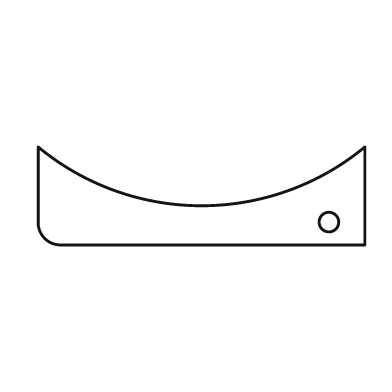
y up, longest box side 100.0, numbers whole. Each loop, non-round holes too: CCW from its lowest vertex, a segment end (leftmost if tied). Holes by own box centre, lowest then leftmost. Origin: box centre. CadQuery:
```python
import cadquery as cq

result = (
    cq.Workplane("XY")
    .moveTo(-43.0, -15.0)
    .lineTo(50.0, -15.0)
    .lineTo(50.0, 15.0)
    .threePointArc((0.0, -3.0), (-50.0, 15.0))
    .lineTo(-50.0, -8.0)
    .threePointArc((-48.0, -13.0), (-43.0, -15.0))
    .close()
    .moveTo(39.0, -8.0)
    .circle(3.0)
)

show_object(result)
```